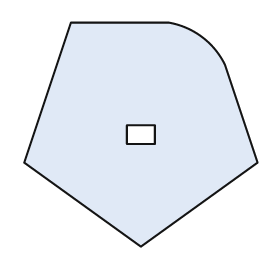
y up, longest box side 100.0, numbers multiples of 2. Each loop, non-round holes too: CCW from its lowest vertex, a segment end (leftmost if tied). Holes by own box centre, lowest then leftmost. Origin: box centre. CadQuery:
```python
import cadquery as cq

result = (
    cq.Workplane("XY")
    .moveTo(0.0, -48.0)
    .lineTo(50.0, -12.0)
    .lineTo(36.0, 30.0)
    .threePointArc((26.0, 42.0), (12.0, 48.0))
    .lineTo(-30.0, 48.0)
    .lineTo(-50.0, -12.0)
    .close()
    .moveTo(-6.0, -4.0)
    .lineTo(6.0, -4.0)
    .lineTo(6.0, 4.0)
    .lineTo(-6.0, 4.0)
    .close()
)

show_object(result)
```